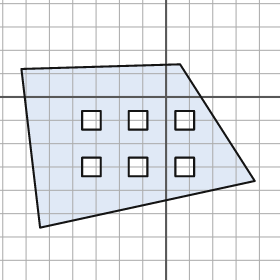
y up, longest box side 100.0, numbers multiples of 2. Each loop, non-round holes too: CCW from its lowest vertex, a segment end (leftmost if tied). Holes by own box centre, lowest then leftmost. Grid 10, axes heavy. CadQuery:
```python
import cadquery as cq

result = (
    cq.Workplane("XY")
    .moveTo(-54.0, -56.0)
    .lineTo(38.0, -36.0)
    .lineTo(6.0, 14.0)
    .lineTo(-62.0, 12.0)
    .close()
    .moveTo(-36.0, -34.0)
    .lineTo(-28.0, -34.0)
    .lineTo(-28.0, -26.0)
    .lineTo(-36.0, -26.0)
    .close()
    .moveTo(-16.0, -34.0)
    .lineTo(-8.0, -34.0)
    .lineTo(-8.0, -26.0)
    .lineTo(-16.0, -26.0)
    .close()
    .moveTo(4.0, -34.0)
    .lineTo(12.0, -34.0)
    .lineTo(12.0, -26.0)
    .lineTo(4.0, -26.0)
    .close()
    .moveTo(-36.0, -14.0)
    .lineTo(-28.0, -14.0)
    .lineTo(-28.0, -6.0)
    .lineTo(-36.0, -6.0)
    .close()
    .moveTo(-16.0, -14.0)
    .lineTo(-8.0, -14.0)
    .lineTo(-8.0, -6.0)
    .lineTo(-16.0, -6.0)
    .close()
    .moveTo(4.0, -14.0)
    .lineTo(12.0, -14.0)
    .lineTo(12.0, -6.0)
    .lineTo(4.0, -6.0)
    .close()
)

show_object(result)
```